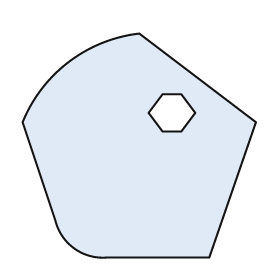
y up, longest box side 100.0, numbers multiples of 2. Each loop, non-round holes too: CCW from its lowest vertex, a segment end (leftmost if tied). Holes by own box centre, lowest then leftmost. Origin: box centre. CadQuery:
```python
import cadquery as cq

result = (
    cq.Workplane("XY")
    .moveTo(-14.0, -48.0)
    .lineTo(30.0, -48.0)
    .lineTo(50.0, 10.0)
    .lineTo(0.0, 48.0)
    .threePointArc((-30.0, 36.0), (-50.0, 10.0))
    .lineTo(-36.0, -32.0)
    .threePointArc((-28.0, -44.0), (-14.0, -48.0))
    .close()
    .moveTo(10.0, 6.0)
    .lineTo(18.0, 6.0)
    .lineTo(24.0, 14.0)
    .lineTo(18.0, 22.0)
    .lineTo(10.0, 22.0)
    .lineTo(4.0, 14.0)
    .close()
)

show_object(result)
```